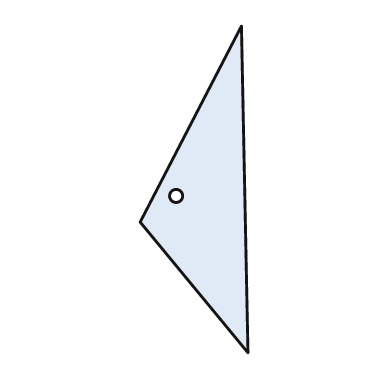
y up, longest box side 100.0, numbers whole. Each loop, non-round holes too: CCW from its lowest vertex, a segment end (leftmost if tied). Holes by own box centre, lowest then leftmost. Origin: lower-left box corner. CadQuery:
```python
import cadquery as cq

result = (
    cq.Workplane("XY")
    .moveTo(33.0, 0.0)
    .lineTo(31.0, 100.0)
    .lineTo(0.0, 40.0)
    .close()
    .moveTo(11.0, 48.0)
    .circle(2.0)
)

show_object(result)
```